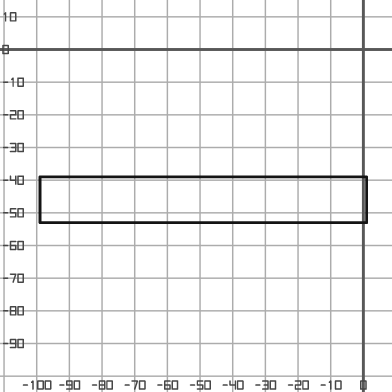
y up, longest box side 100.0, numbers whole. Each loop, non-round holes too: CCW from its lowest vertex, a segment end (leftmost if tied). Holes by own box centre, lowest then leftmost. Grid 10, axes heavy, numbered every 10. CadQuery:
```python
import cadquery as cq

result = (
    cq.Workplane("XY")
    .moveTo(-99.0, -53.0)
    .lineTo(1.0, -53.0)
    .lineTo(1.0, -39.0)
    .lineTo(-99.0, -39.0)
    .close()
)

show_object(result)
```